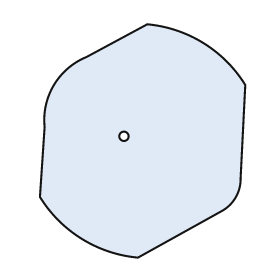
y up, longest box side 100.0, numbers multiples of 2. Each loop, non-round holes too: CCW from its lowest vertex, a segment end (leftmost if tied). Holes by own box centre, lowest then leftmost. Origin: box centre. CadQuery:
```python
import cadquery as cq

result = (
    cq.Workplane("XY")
    .moveTo(-2.0, -50.0)
    .lineTo(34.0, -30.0)
    .threePointArc((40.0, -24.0), (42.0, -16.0))
    .lineTo(44.0, 24.0)
    .threePointArc((26.0, 42.0), (2.0, 50.0))
    .lineTo(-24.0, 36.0)
    .threePointArc((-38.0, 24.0), (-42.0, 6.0))
    .lineTo(-44.0, -24.0)
    .threePointArc((-26.0, -42.0), (-2.0, -50.0))
    .close()
    .moveTo(-8.0, 2.0)
    .circle(2.0)
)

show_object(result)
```